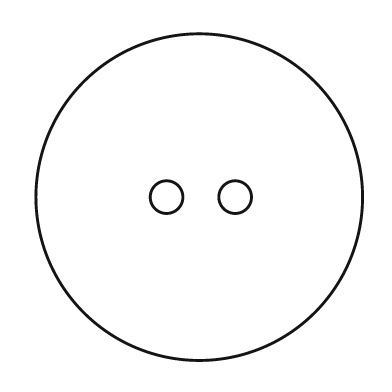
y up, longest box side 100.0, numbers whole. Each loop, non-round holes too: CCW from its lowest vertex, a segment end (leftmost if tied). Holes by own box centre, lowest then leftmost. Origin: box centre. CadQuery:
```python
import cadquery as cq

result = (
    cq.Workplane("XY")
    .moveTo(0.0, 0.0)
    .circle(50.0)
    .moveTo(-10.0, 0.0)
    .circle(5.0)
    .moveTo(11.0, 0.0)
    .circle(5.0)
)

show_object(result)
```